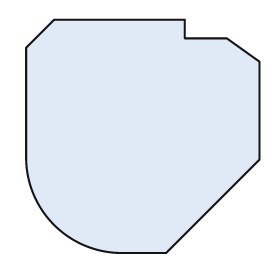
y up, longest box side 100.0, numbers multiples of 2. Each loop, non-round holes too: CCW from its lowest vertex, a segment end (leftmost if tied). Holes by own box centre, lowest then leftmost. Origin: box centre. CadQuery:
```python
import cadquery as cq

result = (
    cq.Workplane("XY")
    .moveTo(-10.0, -50.0)
    .lineTo(10.0, -50.0)
    .lineTo(50.0, -10.0)
    .lineTo(50.0, 32.0)
    .lineTo(36.0, 42.0)
    .lineTo(18.0, 42.0)
    .lineTo(18.0, 50.0)
    .lineTo(-38.0, 50.0)
    .lineTo(-50.0, 38.0)
    .lineTo(-50.0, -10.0)
    .threePointArc((-38.0, -38.0), (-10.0, -50.0))
    .close()
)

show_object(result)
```